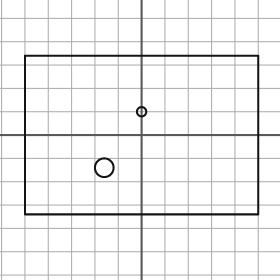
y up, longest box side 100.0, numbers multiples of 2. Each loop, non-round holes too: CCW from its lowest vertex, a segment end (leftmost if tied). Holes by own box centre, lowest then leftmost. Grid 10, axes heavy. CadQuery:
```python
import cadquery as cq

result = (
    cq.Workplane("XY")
    .moveTo(-50.0, -34.0)
    .lineTo(50.0, -34.0)
    .lineTo(50.0, 34.0)
    .lineTo(-50.0, 34.0)
    .close()
    .moveTo(-16.0, -14.0)
    .circle(4.0)
    .moveTo(0.0, 10.0)
    .circle(2.0)
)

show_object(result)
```